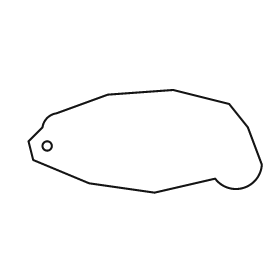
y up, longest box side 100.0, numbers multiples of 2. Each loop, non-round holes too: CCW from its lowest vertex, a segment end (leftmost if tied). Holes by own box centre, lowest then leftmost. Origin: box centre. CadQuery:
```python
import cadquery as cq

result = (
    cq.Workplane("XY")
    .moveTo(4.0, -22.0)
    .lineTo(30.0, -16.0)
    .threePointArc((42.0, -20.0), (50.0, -10.0))
    .lineTo(44.0, 6.0)
    .lineTo(36.0, 16.0)
    .lineTo(12.0, 22.0)
    .lineTo(-16.0, 20.0)
    .lineTo(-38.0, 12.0)
    .threePointArc((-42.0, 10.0), (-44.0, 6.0))
    .lineTo(-50.0, 0.0)
    .lineTo(-48.0, -8.0)
    .lineTo(-24.0, -18.0)
    .close()
    .moveTo(-42.0, -2.0)
    .circle(2.0)
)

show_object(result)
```